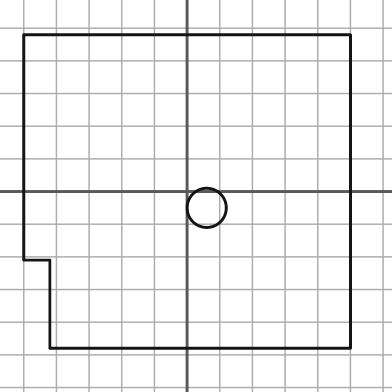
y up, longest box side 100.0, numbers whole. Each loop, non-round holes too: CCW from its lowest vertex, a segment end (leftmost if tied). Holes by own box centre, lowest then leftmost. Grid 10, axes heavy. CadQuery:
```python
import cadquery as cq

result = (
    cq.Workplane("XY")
    .moveTo(-42.0, -48.0)
    .lineTo(50.0, -48.0)
    .lineTo(50.0, 48.0)
    .lineTo(-50.0, 48.0)
    .lineTo(-50.0, -21.0)
    .lineTo(-42.0, -21.0)
    .close()
    .moveTo(6.0, -5.0)
    .circle(6.0)
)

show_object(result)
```